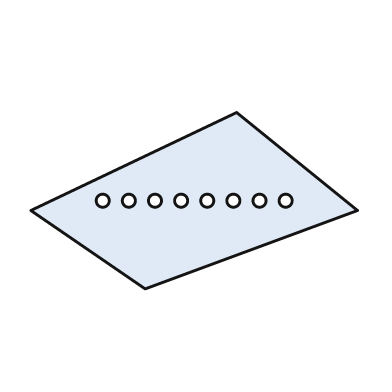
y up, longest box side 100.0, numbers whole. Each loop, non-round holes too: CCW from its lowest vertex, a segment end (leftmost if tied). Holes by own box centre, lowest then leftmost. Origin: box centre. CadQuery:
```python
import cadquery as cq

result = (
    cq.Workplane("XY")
    .moveTo(-15.0, -27.0)
    .lineTo(50.0, -3.0)
    .lineTo(13.0, 27.0)
    .lineTo(-50.0, -3.0)
    .close()
    .moveTo(-28.0, 0.0)
    .circle(2.0)
    .moveTo(-20.0, 0.0)
    .circle(2.0)
    .moveTo(-12.0, 0.0)
    .circle(2.0)
    .moveTo(-4.0, 0.0)
    .circle(2.0)
    .moveTo(4.0, 0.0)
    .circle(2.0)
    .moveTo(12.0, 0.0)
    .circle(2.0)
    .moveTo(20.0, 0.0)
    .circle(2.0)
    .moveTo(28.0, 0.0)
    .circle(2.0)
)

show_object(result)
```